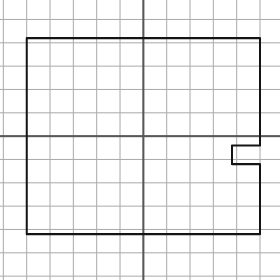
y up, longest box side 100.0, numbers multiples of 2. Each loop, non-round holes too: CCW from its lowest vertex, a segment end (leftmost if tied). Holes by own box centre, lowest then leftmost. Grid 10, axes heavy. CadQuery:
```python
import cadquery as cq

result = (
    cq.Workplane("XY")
    .moveTo(-50.0, -42.0)
    .lineTo(50.0, -42.0)
    .lineTo(50.0, -12.0)
    .lineTo(38.0, -12.0)
    .lineTo(38.0, -4.0)
    .lineTo(50.0, -4.0)
    .lineTo(50.0, 42.0)
    .lineTo(-50.0, 42.0)
    .close()
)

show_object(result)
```